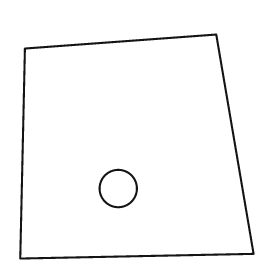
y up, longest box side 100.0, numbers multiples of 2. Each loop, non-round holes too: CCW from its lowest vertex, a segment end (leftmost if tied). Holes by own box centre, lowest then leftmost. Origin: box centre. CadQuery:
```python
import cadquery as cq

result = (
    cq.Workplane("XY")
    .moveTo(-50.0, -48.0)
    .lineTo(50.0, -46.0)
    .lineTo(34.0, 48.0)
    .lineTo(-48.0, 42.0)
    .close()
    .moveTo(-8.0, -18.0)
    .circle(8.0)
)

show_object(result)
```